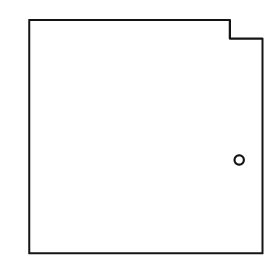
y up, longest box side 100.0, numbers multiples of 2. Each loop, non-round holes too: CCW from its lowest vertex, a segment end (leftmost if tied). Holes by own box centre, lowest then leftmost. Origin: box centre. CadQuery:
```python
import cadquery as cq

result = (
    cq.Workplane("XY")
    .moveTo(-50.0, -50.0)
    .lineTo(50.0, -50.0)
    .lineTo(50.0, 42.0)
    .lineTo(36.0, 42.0)
    .lineTo(36.0, 50.0)
    .lineTo(-50.0, 50.0)
    .close()
    .moveTo(40.0, -10.0)
    .circle(2.0)
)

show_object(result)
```